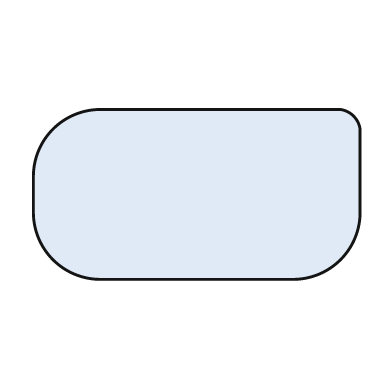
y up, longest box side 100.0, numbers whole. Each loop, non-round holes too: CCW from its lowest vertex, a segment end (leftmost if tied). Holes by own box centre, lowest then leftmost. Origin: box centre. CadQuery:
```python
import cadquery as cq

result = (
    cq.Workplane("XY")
    .moveTo(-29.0, -26.0)
    .lineTo(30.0, -26.0)
    .threePointArc((44.0, -20.0), (50.0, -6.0))
    .lineTo(50.0, 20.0)
    .threePointArc((48.0, 24.0), (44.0, 26.0))
    .lineTo(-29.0, 26.0)
    .threePointArc((-44.0, 20.0), (-50.0, 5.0))
    .lineTo(-50.0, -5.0)
    .threePointArc((-44.0, -20.0), (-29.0, -26.0))
    .close()
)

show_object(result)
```